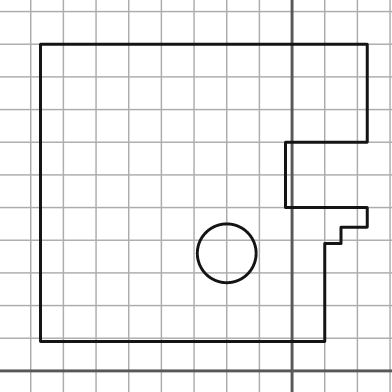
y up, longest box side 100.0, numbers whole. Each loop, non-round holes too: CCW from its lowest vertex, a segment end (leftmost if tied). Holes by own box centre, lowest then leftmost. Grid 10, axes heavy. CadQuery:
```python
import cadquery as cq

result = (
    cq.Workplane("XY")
    .moveTo(-77.0, 9.0)
    .lineTo(10.0, 9.0)
    .lineTo(10.0, 39.0)
    .lineTo(15.0, 39.0)
    .lineTo(15.0, 44.0)
    .lineTo(23.0, 44.0)
    .lineTo(23.0, 50.0)
    .lineTo(-2.0, 50.0)
    .lineTo(-2.0, 70.0)
    .lineTo(23.0, 70.0)
    .lineTo(23.0, 100.0)
    .lineTo(-77.0, 100.0)
    .close()
    .moveTo(-20.0, 36.0)
    .circle(9.0)
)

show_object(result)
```